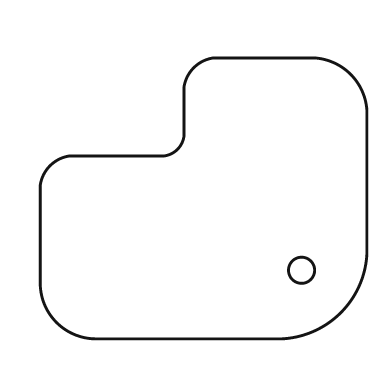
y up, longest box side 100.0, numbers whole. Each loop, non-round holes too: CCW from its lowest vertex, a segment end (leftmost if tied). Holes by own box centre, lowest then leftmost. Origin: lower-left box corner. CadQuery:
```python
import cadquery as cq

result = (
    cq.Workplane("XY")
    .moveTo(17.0, 0.0)
    .lineTo(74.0, 0.0)
    .threePointArc((92.0, 8.0), (100.0, 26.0))
    .lineTo(100.0, 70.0)
    .threePointArc((95.0, 81.0), (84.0, 86.0))
    .lineTo(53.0, 86.0)
    .threePointArc((47.0, 83.0), (44.0, 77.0))
    .lineTo(44.0, 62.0)
    .threePointArc((42.0, 58.0), (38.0, 56.0))
    .lineTo(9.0, 56.0)
    .threePointArc((3.0, 53.0), (0.0, 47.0))
    .lineTo(0.0, 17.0)
    .threePointArc((5.0, 5.0), (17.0, 0.0))
    .close()
    .moveTo(80.0, 21.0)
    .circle(4.0)
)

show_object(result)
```